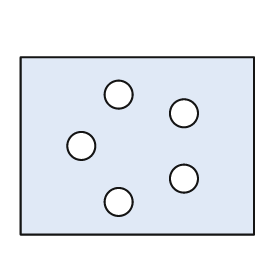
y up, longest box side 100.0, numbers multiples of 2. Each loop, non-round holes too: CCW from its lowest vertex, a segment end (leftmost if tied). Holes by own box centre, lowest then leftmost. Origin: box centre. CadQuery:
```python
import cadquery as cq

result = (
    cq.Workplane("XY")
    .moveTo(-50.0, -38.0)
    .lineTo(50.0, -38.0)
    .lineTo(50.0, 38.0)
    .lineTo(-50.0, 38.0)
    .close()
    .moveTo(-8.0, -24.0)
    .circle(6.0)
    .moveTo(20.0, -14.0)
    .circle(6.0)
    .moveTo(-24.0, 0.0)
    .circle(6.0)
    .moveTo(20.0, 14.0)
    .circle(6.0)
    .moveTo(-8.0, 22.0)
    .circle(6.0)
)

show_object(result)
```